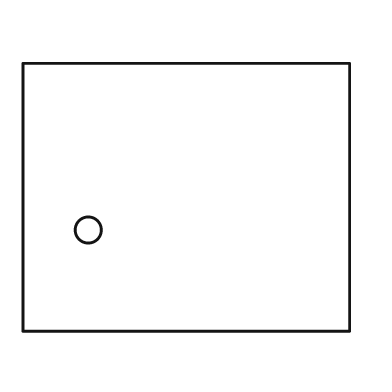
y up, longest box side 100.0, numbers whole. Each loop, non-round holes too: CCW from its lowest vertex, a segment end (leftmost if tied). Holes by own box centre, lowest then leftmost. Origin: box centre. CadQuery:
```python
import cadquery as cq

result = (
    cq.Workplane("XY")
    .moveTo(-50.0, -41.0)
    .lineTo(50.0, -41.0)
    .lineTo(50.0, 41.0)
    .lineTo(-50.0, 41.0)
    .close()
    .moveTo(-30.0, -10.0)
    .circle(4.0)
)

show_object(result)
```